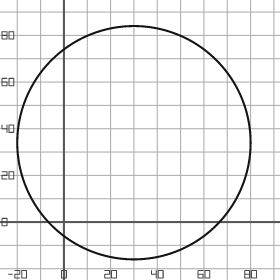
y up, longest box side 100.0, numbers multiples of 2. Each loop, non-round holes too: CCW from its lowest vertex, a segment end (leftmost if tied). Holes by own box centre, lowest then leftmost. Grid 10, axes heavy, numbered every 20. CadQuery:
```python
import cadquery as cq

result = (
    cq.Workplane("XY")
    .moveTo(30.0, 34.0)
    .circle(50.0)
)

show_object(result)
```